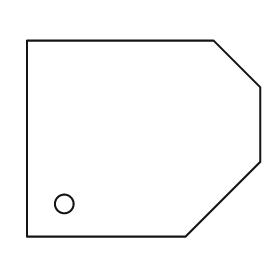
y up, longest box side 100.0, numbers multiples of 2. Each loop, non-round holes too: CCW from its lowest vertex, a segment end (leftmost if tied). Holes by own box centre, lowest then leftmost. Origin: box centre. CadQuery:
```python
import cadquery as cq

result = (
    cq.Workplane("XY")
    .moveTo(-50.0, -42.0)
    .lineTo(18.0, -42.0)
    .lineTo(50.0, -10.0)
    .lineTo(50.0, 22.0)
    .lineTo(30.0, 42.0)
    .lineTo(-50.0, 42.0)
    .close()
    .moveTo(-34.0, -28.0)
    .circle(4.0)
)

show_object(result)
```